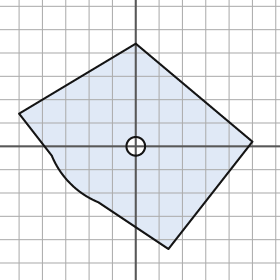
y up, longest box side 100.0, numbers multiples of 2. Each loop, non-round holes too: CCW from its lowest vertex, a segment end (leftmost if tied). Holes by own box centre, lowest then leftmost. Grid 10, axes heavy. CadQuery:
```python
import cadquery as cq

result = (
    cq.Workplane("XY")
    .moveTo(14.0, -44.0)
    .lineTo(50.0, 2.0)
    .lineTo(0.0, 44.0)
    .lineTo(-50.0, 14.0)
    .lineTo(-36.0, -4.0)
    .threePointArc((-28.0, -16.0), (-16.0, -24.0))
    .close()
    .moveTo(0.0, 0.0)
    .circle(4.0)
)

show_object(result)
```